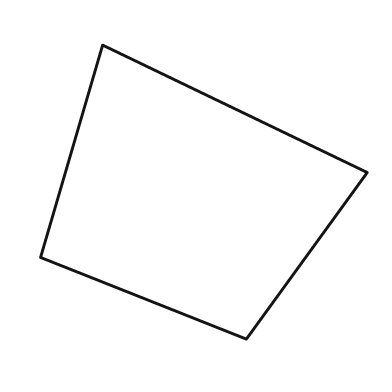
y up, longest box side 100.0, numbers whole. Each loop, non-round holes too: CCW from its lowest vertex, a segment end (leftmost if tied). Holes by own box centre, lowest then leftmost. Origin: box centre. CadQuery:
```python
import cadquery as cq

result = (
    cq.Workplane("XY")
    .moveTo(13.0, -45.0)
    .lineTo(50.0, 6.0)
    .lineTo(-31.0, 45.0)
    .lineTo(-50.0, -20.0)
    .close()
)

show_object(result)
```